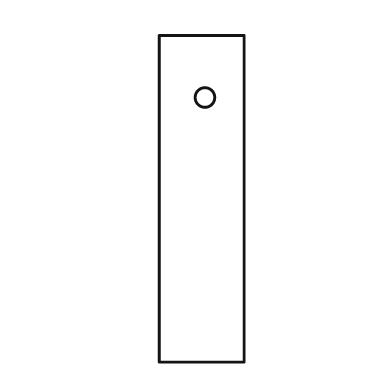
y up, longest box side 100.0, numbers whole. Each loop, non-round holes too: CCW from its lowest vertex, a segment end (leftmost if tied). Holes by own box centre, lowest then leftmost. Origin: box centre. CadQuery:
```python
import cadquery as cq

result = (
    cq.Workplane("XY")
    .moveTo(-13.0, -50.0)
    .lineTo(13.0, -50.0)
    .lineTo(13.0, 50.0)
    .lineTo(-13.0, 50.0)
    .close()
    .moveTo(1.0, 31.0)
    .circle(3.0)
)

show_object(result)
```